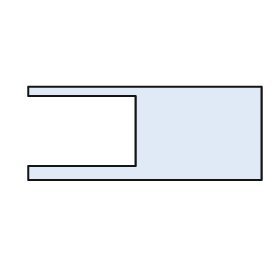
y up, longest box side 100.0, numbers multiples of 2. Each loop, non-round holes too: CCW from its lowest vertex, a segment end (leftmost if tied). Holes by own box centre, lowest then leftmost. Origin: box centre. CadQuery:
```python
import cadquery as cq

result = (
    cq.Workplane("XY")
    .moveTo(-50.0, -20.0)
    .lineTo(50.0, -20.0)
    .lineTo(50.0, 20.0)
    .lineTo(-50.0, 20.0)
    .lineTo(-50.0, 16.0)
    .lineTo(-4.0, 16.0)
    .lineTo(-4.0, -14.0)
    .lineTo(-50.0, -14.0)
    .close()
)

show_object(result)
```